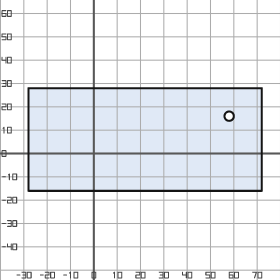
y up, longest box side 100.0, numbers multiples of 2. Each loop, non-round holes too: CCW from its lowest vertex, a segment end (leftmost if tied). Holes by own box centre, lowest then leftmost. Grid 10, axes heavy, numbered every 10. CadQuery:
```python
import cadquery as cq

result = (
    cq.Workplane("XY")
    .moveTo(-28.0, -16.0)
    .lineTo(72.0, -16.0)
    .lineTo(72.0, 28.0)
    .lineTo(-28.0, 28.0)
    .close()
    .moveTo(58.0, 16.0)
    .circle(2.0)
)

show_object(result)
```